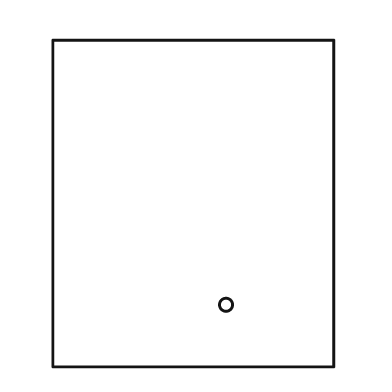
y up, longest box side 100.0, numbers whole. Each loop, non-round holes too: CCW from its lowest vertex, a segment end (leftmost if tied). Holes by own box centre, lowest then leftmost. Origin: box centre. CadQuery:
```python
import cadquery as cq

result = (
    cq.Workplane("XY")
    .moveTo(-43.0, -50.0)
    .lineTo(43.0, -50.0)
    .lineTo(43.0, 50.0)
    .lineTo(-43.0, 50.0)
    .close()
    .moveTo(10.0, -31.0)
    .circle(2.0)
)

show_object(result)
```